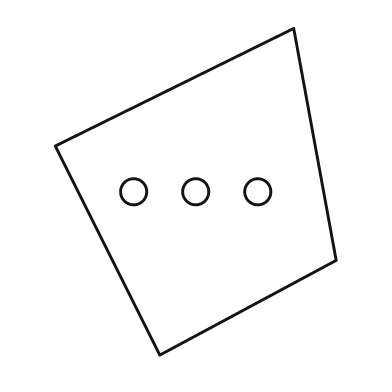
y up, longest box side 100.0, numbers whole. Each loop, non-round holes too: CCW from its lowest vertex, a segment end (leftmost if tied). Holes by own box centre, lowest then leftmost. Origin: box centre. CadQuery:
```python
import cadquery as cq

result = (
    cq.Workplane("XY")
    .moveTo(-11.0, -50.0)
    .lineTo(43.0, -21.0)
    .lineTo(30.0, 50.0)
    .lineTo(-43.0, 14.0)
    .close()
    .moveTo(-19.0, 0.0)
    .circle(4.0)
    .moveTo(0.0, 0.0)
    .circle(4.0)
    .moveTo(19.0, 0.0)
    .circle(4.0)
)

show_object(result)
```